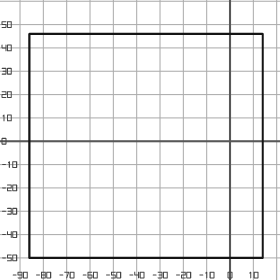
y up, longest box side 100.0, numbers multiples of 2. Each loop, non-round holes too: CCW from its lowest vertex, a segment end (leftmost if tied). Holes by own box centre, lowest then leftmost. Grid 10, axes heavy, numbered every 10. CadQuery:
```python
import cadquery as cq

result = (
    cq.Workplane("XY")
    .moveTo(-86.0, -50.0)
    .lineTo(14.0, -50.0)
    .lineTo(14.0, 46.0)
    .lineTo(-86.0, 46.0)
    .close()
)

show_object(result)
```